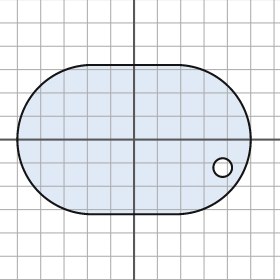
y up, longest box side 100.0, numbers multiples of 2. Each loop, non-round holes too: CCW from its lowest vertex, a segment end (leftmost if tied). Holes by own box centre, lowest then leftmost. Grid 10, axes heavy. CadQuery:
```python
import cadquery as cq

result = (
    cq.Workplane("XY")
    .moveTo(-18.0, -32.0)
    .lineTo(18.0, -32.0)
    .threePointArc((50.0, 0.0), (18.0, 32.0))
    .lineTo(-18.0, 32.0)
    .threePointArc((-50.0, 0.0), (-18.0, -32.0))
    .close()
    .moveTo(38.0, -12.0)
    .circle(4.0)
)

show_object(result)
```